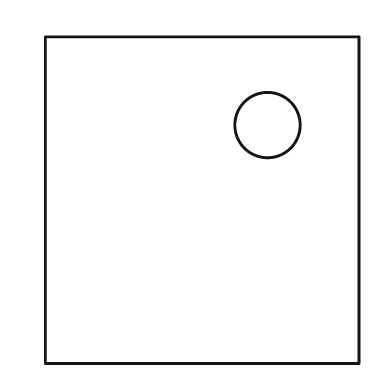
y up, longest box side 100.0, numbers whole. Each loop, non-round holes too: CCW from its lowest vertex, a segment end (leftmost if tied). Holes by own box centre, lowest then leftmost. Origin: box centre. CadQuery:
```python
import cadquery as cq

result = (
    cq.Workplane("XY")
    .moveTo(-48.0, -50.0)
    .lineTo(48.0, -50.0)
    .lineTo(48.0, 50.0)
    .lineTo(-48.0, 50.0)
    .close()
    .moveTo(20.0, 23.0)
    .circle(10.0)
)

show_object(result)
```